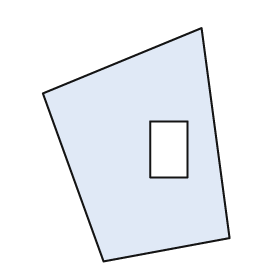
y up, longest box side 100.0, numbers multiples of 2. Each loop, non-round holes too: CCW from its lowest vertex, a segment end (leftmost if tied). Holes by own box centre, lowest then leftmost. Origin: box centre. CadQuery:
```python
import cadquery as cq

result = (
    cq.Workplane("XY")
    .moveTo(-14.0, -50.0)
    .lineTo(40.0, -40.0)
    .lineTo(28.0, 50.0)
    .lineTo(-40.0, 22.0)
    .close()
    .moveTo(6.0, -14.0)
    .lineTo(22.0, -14.0)
    .lineTo(22.0, 10.0)
    .lineTo(6.0, 10.0)
    .close()
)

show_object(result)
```